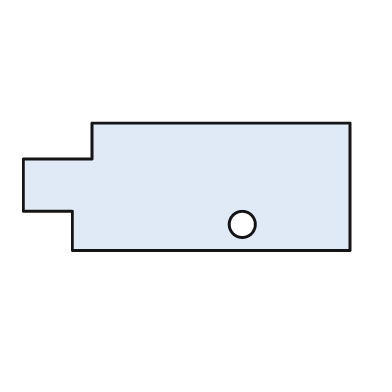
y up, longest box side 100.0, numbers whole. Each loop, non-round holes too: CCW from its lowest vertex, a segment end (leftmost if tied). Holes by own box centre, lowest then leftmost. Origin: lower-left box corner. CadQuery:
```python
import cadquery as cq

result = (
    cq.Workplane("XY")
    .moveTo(15.0, 0.0)
    .lineTo(100.0, 0.0)
    .lineTo(100.0, 39.0)
    .lineTo(21.0, 39.0)
    .lineTo(21.0, 28.0)
    .lineTo(0.0, 28.0)
    .lineTo(0.0, 12.0)
    .lineTo(15.0, 12.0)
    .close()
    .moveTo(67.0, 8.0)
    .circle(4.0)
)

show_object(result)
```